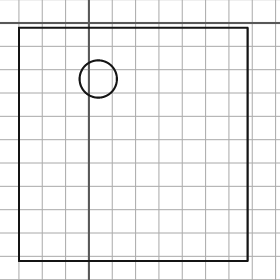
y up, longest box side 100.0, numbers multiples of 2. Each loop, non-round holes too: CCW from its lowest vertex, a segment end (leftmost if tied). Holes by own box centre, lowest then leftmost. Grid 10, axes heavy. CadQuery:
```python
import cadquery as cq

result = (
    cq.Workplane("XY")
    .moveTo(-30.0, -102.0)
    .lineTo(68.0, -102.0)
    .lineTo(68.0, -2.0)
    .lineTo(-30.0, -2.0)
    .close()
    .moveTo(4.0, -24.0)
    .circle(8.0)
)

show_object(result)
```